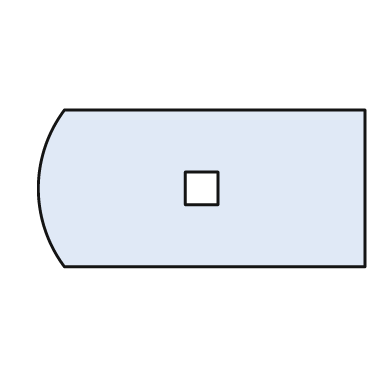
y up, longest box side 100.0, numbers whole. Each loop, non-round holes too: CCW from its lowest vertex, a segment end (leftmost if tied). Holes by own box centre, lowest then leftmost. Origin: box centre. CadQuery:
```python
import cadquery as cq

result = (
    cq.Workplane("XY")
    .moveTo(-42.0, -24.0)
    .lineTo(50.0, -24.0)
    .lineTo(50.0, 24.0)
    .lineTo(-42.0, 24.0)
    .threePointArc((-50.0, 0.0), (-42.0, -24.0))
    .close()
    .moveTo(-5.0, -5.0)
    .lineTo(5.0, -5.0)
    .lineTo(5.0, 5.0)
    .lineTo(-5.0, 5.0)
    .close()
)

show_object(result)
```